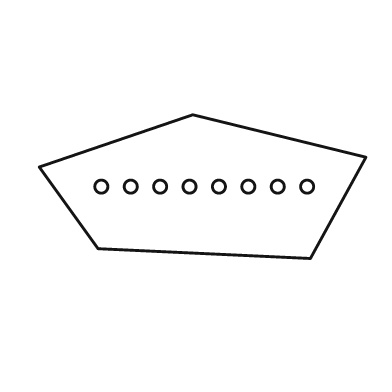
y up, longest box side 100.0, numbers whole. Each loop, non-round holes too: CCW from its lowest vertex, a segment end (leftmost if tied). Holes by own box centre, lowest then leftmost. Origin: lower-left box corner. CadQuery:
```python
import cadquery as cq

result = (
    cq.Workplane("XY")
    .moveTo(83.0, 0.0)
    .lineTo(100.0, 31.0)
    .lineTo(47.0, 44.0)
    .lineTo(0.0, 28.0)
    .lineTo(18.0, 3.0)
    .close()
    .moveTo(19.0, 22.0)
    .circle(2.0)
    .moveTo(28.0, 22.0)
    .circle(2.0)
    .moveTo(37.0, 22.0)
    .circle(2.0)
    .moveTo(46.0, 22.0)
    .circle(2.0)
    .moveTo(55.0, 22.0)
    .circle(2.0)
    .moveTo(64.0, 22.0)
    .circle(2.0)
    .moveTo(73.0, 22.0)
    .circle(2.0)
    .moveTo(82.0, 22.0)
    .circle(2.0)
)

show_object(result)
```